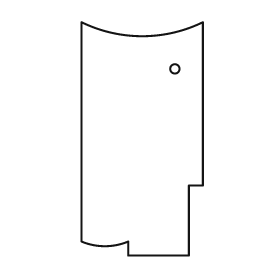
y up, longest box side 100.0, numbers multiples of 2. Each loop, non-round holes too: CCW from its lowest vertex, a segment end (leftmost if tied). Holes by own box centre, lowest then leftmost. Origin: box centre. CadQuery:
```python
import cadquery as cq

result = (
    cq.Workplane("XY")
    .moveTo(-6.0, -50.0)
    .lineTo(20.0, -50.0)
    .lineTo(20.0, -20.0)
    .lineTo(26.0, -20.0)
    .lineTo(26.0, 50.0)
    .threePointArc((0.0, 44.0), (-26.0, 50.0))
    .lineTo(-26.0, -44.0)
    .threePointArc((-16.0, -46.0), (-6.0, -44.0))
    .close()
    .moveTo(14.0, 30.0)
    .circle(2.0)
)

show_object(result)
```